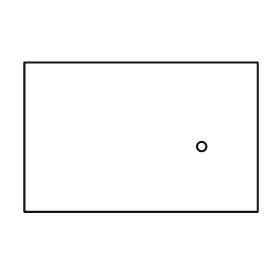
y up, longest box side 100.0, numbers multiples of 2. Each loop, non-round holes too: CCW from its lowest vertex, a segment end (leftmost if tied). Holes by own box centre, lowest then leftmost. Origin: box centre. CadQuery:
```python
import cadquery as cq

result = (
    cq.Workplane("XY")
    .moveTo(-50.0, -32.0)
    .lineTo(50.0, -32.0)
    .lineTo(50.0, 32.0)
    .lineTo(-50.0, 32.0)
    .close()
    .moveTo(26.0, -4.0)
    .circle(2.0)
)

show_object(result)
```